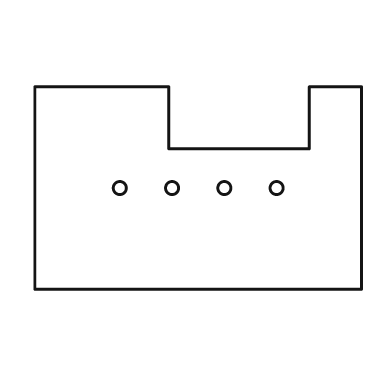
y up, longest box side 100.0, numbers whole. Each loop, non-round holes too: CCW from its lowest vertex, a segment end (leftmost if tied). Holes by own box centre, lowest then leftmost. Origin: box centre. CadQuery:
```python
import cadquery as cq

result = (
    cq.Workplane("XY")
    .moveTo(-50.0, -31.0)
    .lineTo(50.0, -31.0)
    .lineTo(50.0, 31.0)
    .lineTo(34.0, 31.0)
    .lineTo(34.0, 12.0)
    .lineTo(-9.0, 12.0)
    .lineTo(-9.0, 31.0)
    .lineTo(-50.0, 31.0)
    .close()
    .moveTo(-24.0, 0.0)
    .circle(2.0)
    .moveTo(-8.0, 0.0)
    .circle(2.0)
    .moveTo(8.0, 0.0)
    .circle(2.0)
    .moveTo(24.0, 0.0)
    .circle(2.0)
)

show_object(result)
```